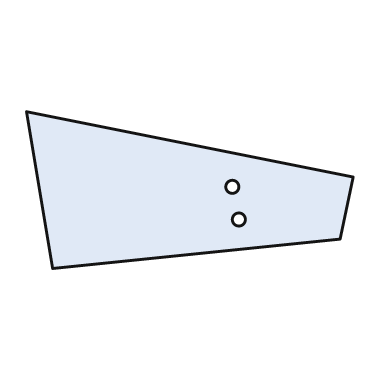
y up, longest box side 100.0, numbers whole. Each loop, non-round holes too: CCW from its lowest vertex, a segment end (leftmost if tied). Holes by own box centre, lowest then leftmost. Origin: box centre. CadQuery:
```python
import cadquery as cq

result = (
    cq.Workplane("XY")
    .moveTo(-42.0, -24.0)
    .lineTo(46.0, -15.0)
    .lineTo(50.0, 4.0)
    .lineTo(-50.0, 24.0)
    .close()
    .moveTo(15.0, -9.0)
    .circle(2.0)
    .moveTo(13.0, 1.0)
    .circle(2.0)
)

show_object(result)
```